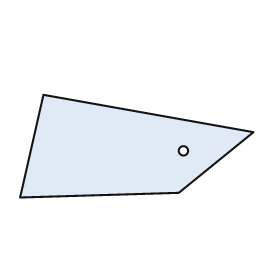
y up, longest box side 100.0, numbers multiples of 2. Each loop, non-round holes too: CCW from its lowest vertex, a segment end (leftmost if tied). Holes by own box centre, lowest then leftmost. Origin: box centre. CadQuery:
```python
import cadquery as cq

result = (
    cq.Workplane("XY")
    .moveTo(-50.0, -22.0)
    .lineTo(18.0, -20.0)
    .lineTo(50.0, 6.0)
    .lineTo(-40.0, 22.0)
    .close()
    .moveTo(20.0, -2.0)
    .circle(2.0)
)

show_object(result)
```